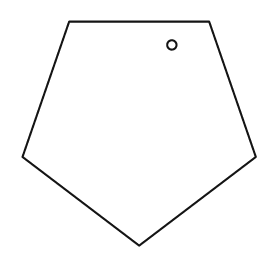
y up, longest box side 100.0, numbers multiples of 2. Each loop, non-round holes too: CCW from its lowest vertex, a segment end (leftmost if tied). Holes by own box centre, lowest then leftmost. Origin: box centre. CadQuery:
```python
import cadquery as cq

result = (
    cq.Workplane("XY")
    .moveTo(0.0, -48.0)
    .lineTo(50.0, -10.0)
    .lineTo(30.0, 48.0)
    .lineTo(-30.0, 48.0)
    .lineTo(-50.0, -10.0)
    .close()
    .moveTo(14.0, 38.0)
    .circle(2.0)
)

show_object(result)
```